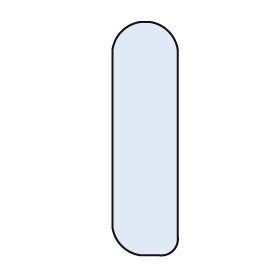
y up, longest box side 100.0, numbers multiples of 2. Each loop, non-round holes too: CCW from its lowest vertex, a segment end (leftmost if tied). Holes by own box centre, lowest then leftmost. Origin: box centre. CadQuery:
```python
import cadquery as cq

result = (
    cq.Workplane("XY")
    .moveTo(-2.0, -50.0)
    .lineTo(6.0, -50.0)
    .threePointArc((12.0, -48.0), (14.0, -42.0))
    .lineTo(14.0, 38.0)
    .threePointArc((10.0, 46.0), (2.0, 50.0))
    .lineTo(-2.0, 50.0)
    .threePointArc((-10.0, 46.0), (-14.0, 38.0))
    .lineTo(-14.0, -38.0)
    .threePointArc((-10.0, -46.0), (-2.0, -50.0))
    .close()
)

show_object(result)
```